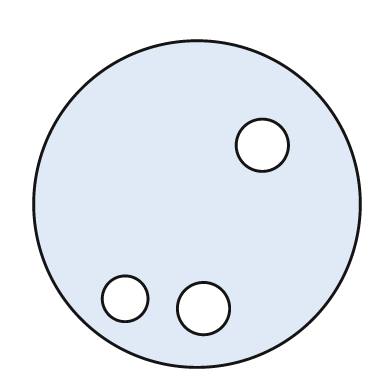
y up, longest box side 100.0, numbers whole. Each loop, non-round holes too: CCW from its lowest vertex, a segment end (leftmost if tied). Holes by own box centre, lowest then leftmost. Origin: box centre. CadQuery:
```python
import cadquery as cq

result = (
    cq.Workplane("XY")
    .moveTo(0.0, 0.0)
    .circle(50.0)
    .moveTo(2.0, -32.0)
    .circle(8.0)
    .moveTo(-22.0, -29.0)
    .circle(7.0)
    .moveTo(20.0, 18.0)
    .circle(8.0)
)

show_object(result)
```